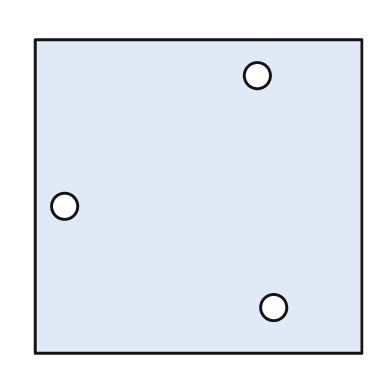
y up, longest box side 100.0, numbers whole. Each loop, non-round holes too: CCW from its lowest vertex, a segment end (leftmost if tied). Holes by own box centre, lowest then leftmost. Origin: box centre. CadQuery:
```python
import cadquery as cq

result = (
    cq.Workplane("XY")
    .moveTo(-50.0, -48.0)
    .lineTo(50.0, -48.0)
    .lineTo(50.0, 48.0)
    .lineTo(-50.0, 48.0)
    .close()
    .moveTo(23.0, -34.0)
    .circle(4.0)
    .moveTo(-41.0, -3.0)
    .circle(4.0)
    .moveTo(18.0, 37.0)
    .circle(4.0)
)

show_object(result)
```